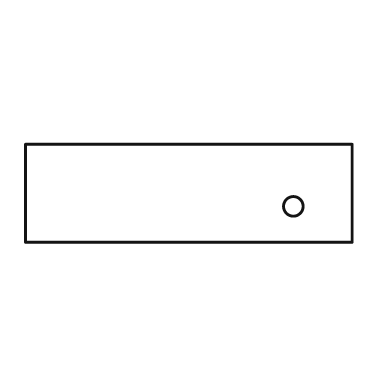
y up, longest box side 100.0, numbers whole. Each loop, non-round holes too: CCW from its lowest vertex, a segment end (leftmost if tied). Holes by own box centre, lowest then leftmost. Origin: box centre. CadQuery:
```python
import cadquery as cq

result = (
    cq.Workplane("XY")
    .moveTo(-50.0, -15.0)
    .lineTo(50.0, -15.0)
    .lineTo(50.0, 15.0)
    .lineTo(-50.0, 15.0)
    .close()
    .moveTo(32.0, -4.0)
    .circle(3.0)
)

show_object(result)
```